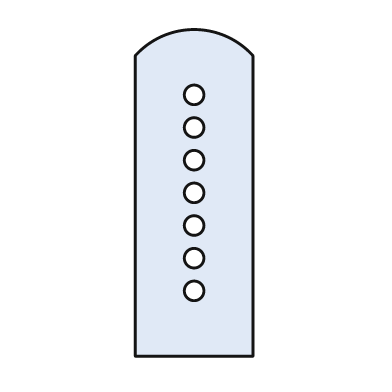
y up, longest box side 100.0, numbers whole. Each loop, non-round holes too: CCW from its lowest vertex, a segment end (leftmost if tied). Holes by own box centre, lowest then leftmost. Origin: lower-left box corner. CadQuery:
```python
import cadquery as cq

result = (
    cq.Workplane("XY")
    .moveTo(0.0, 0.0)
    .lineTo(36.0, 0.0)
    .lineTo(36.0, 92.0)
    .threePointArc((18.0, 100.0), (0.0, 92.0))
    .close()
    .moveTo(18.0, 20.0)
    .circle(3.0)
    .moveTo(18.0, 30.0)
    .circle(3.0)
    .moveTo(18.0, 40.0)
    .circle(3.0)
    .moveTo(18.0, 50.0)
    .circle(3.0)
    .moveTo(18.0, 60.0)
    .circle(3.0)
    .moveTo(18.0, 70.0)
    .circle(3.0)
    .moveTo(18.0, 80.0)
    .circle(3.0)
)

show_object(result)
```